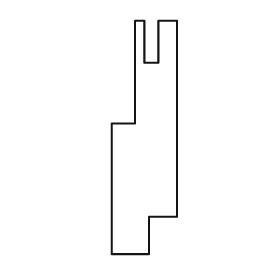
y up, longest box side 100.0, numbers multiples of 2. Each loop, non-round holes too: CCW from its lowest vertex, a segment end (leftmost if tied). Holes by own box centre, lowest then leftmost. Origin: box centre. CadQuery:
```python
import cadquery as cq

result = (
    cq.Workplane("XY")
    .moveTo(-14.0, -50.0)
    .lineTo(2.0, -50.0)
    .lineTo(2.0, -34.0)
    .lineTo(14.0, -34.0)
    .lineTo(14.0, 50.0)
    .lineTo(6.0, 50.0)
    .lineTo(6.0, 32.0)
    .lineTo(0.0, 32.0)
    .lineTo(0.0, 50.0)
    .lineTo(-4.0, 50.0)
    .lineTo(-4.0, 6.0)
    .lineTo(-14.0, 6.0)
    .close()
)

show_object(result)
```